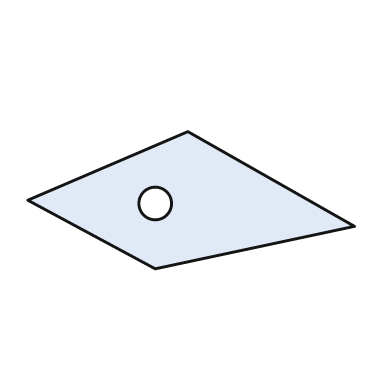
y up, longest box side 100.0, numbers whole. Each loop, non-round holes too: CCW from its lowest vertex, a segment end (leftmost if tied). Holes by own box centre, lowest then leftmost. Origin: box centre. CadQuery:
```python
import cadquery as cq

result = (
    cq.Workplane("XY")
    .moveTo(-11.0, -21.0)
    .lineTo(50.0, -8.0)
    .lineTo(-1.0, 21.0)
    .lineTo(-50.0, 0.0)
    .close()
    .moveTo(-11.0, -1.0)
    .circle(5.0)
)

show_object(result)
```